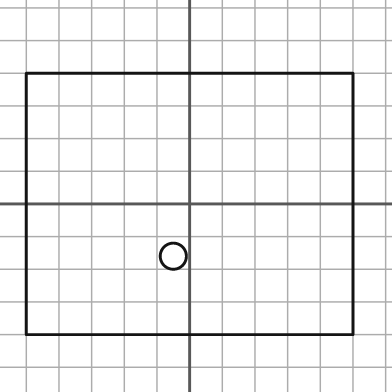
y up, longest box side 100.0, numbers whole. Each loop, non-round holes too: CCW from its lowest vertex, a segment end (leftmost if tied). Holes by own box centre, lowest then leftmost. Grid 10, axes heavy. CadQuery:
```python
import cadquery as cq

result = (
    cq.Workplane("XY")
    .moveTo(-50.0, -40.0)
    .lineTo(50.0, -40.0)
    .lineTo(50.0, 40.0)
    .lineTo(-50.0, 40.0)
    .close()
    .moveTo(-5.0, -16.0)
    .circle(4.0)
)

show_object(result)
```